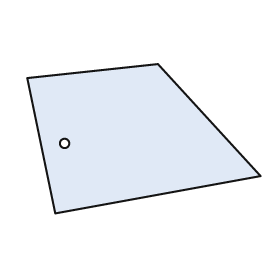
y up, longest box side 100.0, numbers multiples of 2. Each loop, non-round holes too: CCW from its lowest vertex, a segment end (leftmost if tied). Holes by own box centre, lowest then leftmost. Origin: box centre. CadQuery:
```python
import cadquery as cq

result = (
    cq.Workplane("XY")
    .moveTo(-38.0, -32.0)
    .lineTo(50.0, -16.0)
    .lineTo(6.0, 32.0)
    .lineTo(-50.0, 26.0)
    .close()
    .moveTo(-34.0, -2.0)
    .circle(2.0)
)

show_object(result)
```